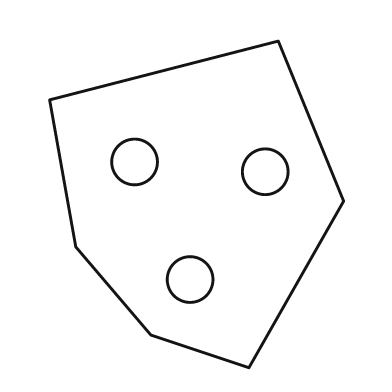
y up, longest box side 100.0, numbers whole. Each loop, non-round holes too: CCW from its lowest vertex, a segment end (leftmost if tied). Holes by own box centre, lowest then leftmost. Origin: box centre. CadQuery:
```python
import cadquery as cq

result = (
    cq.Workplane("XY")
    .moveTo(16.0, -50.0)
    .lineTo(45.0, 1.0)
    .lineTo(25.0, 50.0)
    .lineTo(-45.0, 32.0)
    .lineTo(-37.0, -13.0)
    .lineTo(-14.0, -40.0)
    .close()
    .moveTo(-2.0, -23.0)
    .circle(7.0)
    .moveTo(21.0, 10.0)
    .circle(7.0)
    .moveTo(-19.0, 13.0)
    .circle(7.0)
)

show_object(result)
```